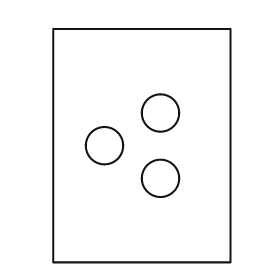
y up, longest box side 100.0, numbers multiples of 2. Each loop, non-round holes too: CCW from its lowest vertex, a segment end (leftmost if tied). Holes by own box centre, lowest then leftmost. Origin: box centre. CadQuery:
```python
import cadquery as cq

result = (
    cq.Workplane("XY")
    .moveTo(-38.0, -50.0)
    .lineTo(38.0, -50.0)
    .lineTo(38.0, 50.0)
    .lineTo(-38.0, 50.0)
    .close()
    .moveTo(8.0, -14.0)
    .circle(8.0)
    .moveTo(-16.0, 0.0)
    .circle(8.0)
    .moveTo(8.0, 14.0)
    .circle(8.0)
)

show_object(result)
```